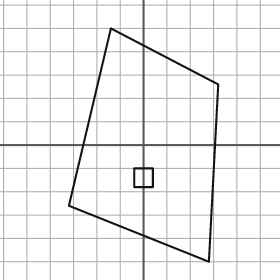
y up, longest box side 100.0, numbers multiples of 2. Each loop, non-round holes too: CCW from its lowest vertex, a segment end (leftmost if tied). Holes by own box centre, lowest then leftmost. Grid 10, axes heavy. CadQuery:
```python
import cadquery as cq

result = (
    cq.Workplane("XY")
    .moveTo(28.0, -50.0)
    .lineTo(32.0, 26.0)
    .lineTo(-14.0, 50.0)
    .lineTo(-32.0, -26.0)
    .close()
    .moveTo(-4.0, -18.0)
    .lineTo(4.0, -18.0)
    .lineTo(4.0, -10.0)
    .lineTo(-4.0, -10.0)
    .close()
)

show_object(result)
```